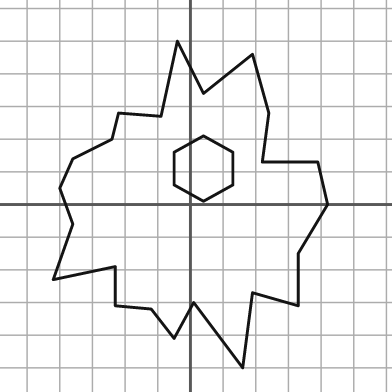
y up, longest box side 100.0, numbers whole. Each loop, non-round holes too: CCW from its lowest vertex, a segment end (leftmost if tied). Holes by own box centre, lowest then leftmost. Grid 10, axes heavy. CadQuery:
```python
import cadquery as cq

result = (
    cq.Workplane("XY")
    .moveTo(16.0, -50.0)
    .lineTo(19.0, -27.0)
    .lineTo(33.0, -31.0)
    .lineTo(33.0, -15.0)
    .lineTo(42.0, 0.0)
    .lineTo(39.0, 13.0)
    .lineTo(22.0, 13.0)
    .lineTo(24.0, 28.0)
    .lineTo(19.0, 46.0)
    .lineTo(4.0, 34.0)
    .lineTo(-4.0, 50.0)
    .lineTo(-9.0, 27.0)
    .lineTo(-22.0, 28.0)
    .lineTo(-24.0, 20.0)
    .lineTo(-36.0, 14.0)
    .lineTo(-40.0, 5.0)
    .lineTo(-36.0, -6.0)
    .lineTo(-42.0, -23.0)
    .lineTo(-23.0, -19.0)
    .lineTo(-23.0, -31.0)
    .lineTo(-12.0, -32.0)
    .lineTo(-5.0, -41.0)
    .lineTo(1.0, -30.0)
    .close()
    .moveTo(4.0, 1.0)
    .lineTo(13.0, 6.0)
    .lineTo(13.0, 16.0)
    .lineTo(4.0, 21.0)
    .lineTo(-5.0, 16.0)
    .lineTo(-5.0, 6.0)
    .close()
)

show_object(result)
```